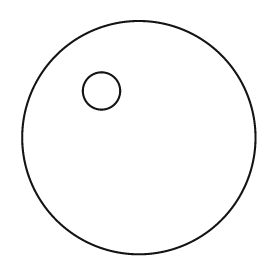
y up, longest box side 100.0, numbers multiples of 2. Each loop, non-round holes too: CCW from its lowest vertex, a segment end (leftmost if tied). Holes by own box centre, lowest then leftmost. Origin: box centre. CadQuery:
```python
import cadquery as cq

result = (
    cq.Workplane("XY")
    .moveTo(0.0, 0.0)
    .circle(50.0)
    .moveTo(-16.0, 20.0)
    .circle(8.0)
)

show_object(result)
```